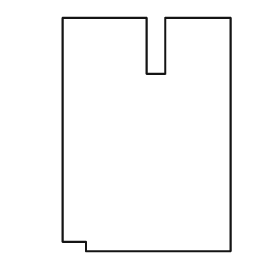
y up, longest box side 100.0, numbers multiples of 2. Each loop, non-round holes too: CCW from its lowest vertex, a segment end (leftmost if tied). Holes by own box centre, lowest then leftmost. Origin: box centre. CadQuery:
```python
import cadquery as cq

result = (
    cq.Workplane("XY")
    .moveTo(-26.0, -50.0)
    .lineTo(36.0, -50.0)
    .lineTo(36.0, 50.0)
    .lineTo(8.0, 50.0)
    .lineTo(8.0, 26.0)
    .lineTo(0.0, 26.0)
    .lineTo(0.0, 50.0)
    .lineTo(-36.0, 50.0)
    .lineTo(-36.0, -46.0)
    .lineTo(-26.0, -46.0)
    .close()
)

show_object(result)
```